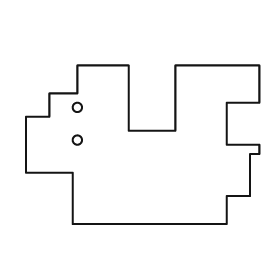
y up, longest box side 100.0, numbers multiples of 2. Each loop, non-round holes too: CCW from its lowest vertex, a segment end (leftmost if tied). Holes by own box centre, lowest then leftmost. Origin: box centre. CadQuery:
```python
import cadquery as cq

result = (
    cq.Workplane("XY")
    .moveTo(-30.0, -34.0)
    .lineTo(36.0, -34.0)
    .lineTo(36.0, -22.0)
    .lineTo(46.0, -22.0)
    .lineTo(46.0, -4.0)
    .lineTo(50.0, -4.0)
    .lineTo(50.0, 0.0)
    .lineTo(36.0, 0.0)
    .lineTo(36.0, 18.0)
    .lineTo(50.0, 18.0)
    .lineTo(50.0, 34.0)
    .lineTo(14.0, 34.0)
    .lineTo(14.0, 6.0)
    .lineTo(-6.0, 6.0)
    .lineTo(-6.0, 34.0)
    .lineTo(-28.0, 34.0)
    .lineTo(-28.0, 22.0)
    .lineTo(-40.0, 22.0)
    .lineTo(-40.0, 12.0)
    .lineTo(-50.0, 12.0)
    .lineTo(-50.0, -12.0)
    .lineTo(-30.0, -12.0)
    .close()
    .moveTo(-28.0, 2.0)
    .circle(2.0)
    .moveTo(-28.0, 16.0)
    .circle(2.0)
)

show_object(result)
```